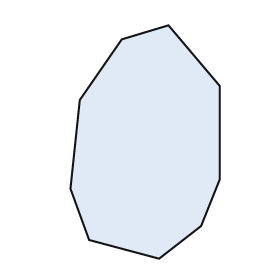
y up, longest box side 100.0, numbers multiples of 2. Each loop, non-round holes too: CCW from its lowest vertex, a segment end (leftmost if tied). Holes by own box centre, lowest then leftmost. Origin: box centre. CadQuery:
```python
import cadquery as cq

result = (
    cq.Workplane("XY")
    .moveTo(6.0, -50.0)
    .lineTo(24.0, -36.0)
    .lineTo(32.0, -16.0)
    .lineTo(32.0, 24.0)
    .lineTo(10.0, 50.0)
    .lineTo(-10.0, 44.0)
    .lineTo(-28.0, 18.0)
    .lineTo(-32.0, -20.0)
    .lineTo(-24.0, -42.0)
    .close()
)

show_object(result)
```